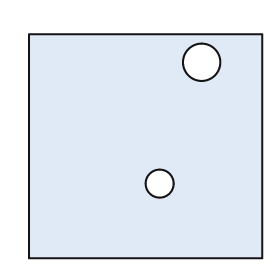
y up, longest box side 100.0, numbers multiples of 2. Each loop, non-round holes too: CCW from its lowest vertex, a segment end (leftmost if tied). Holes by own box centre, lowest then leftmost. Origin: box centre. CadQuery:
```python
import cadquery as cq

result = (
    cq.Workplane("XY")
    .moveTo(-50.0, -48.0)
    .lineTo(50.0, -48.0)
    .lineTo(50.0, 48.0)
    .lineTo(-50.0, 48.0)
    .close()
    .moveTo(6.0, -16.0)
    .circle(6.0)
    .moveTo(24.0, 36.0)
    .circle(8.0)
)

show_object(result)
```